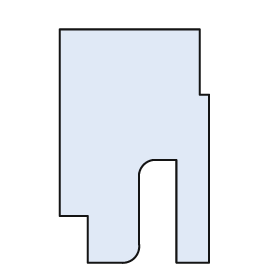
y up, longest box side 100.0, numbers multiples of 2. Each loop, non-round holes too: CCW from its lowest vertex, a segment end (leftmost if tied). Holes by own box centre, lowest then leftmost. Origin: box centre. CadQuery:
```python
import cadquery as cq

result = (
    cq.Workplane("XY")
    .moveTo(-20.0, -50.0)
    .lineTo(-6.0, -50.0)
    .threePointArc((0.0, -48.0), (2.0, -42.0))
    .lineTo(2.0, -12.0)
    .threePointArc((4.0, -8.0), (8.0, -6.0))
    .lineTo(18.0, -6.0)
    .lineTo(18.0, -50.0)
    .lineTo(32.0, -50.0)
    .lineTo(32.0, 22.0)
    .lineTo(28.0, 22.0)
    .lineTo(28.0, 50.0)
    .lineTo(-32.0, 50.0)
    .lineTo(-32.0, -30.0)
    .lineTo(-20.0, -30.0)
    .close()
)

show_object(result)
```